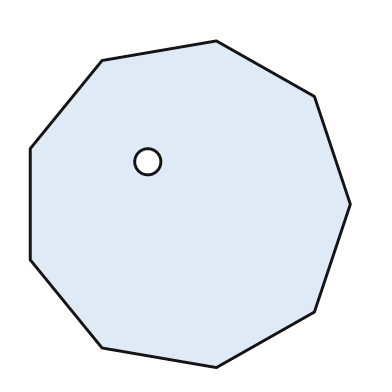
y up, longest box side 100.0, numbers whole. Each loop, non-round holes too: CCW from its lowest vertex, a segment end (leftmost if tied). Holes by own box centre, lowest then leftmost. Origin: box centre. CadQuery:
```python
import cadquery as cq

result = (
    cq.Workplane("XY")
    .moveTo(8.0, -50.0)
    .lineTo(38.0, -33.0)
    .lineTo(49.0, 0.0)
    .lineTo(38.0, 33.0)
    .lineTo(8.0, 50.0)
    .lineTo(-27.0, 44.0)
    .lineTo(-49.0, 17.0)
    .lineTo(-49.0, -17.0)
    .lineTo(-27.0, -44.0)
    .close()
    .moveTo(-13.0, 13.0)
    .circle(4.0)
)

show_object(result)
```